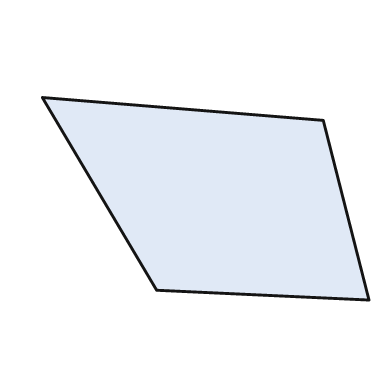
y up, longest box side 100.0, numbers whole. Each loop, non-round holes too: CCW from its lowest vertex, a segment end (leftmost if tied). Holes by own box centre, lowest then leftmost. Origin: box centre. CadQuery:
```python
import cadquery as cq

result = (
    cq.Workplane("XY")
    .moveTo(50.0, -31.0)
    .lineTo(36.0, 24.0)
    .lineTo(-50.0, 31.0)
    .lineTo(-15.0, -28.0)
    .close()
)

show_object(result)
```